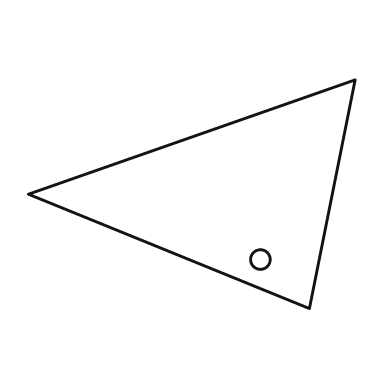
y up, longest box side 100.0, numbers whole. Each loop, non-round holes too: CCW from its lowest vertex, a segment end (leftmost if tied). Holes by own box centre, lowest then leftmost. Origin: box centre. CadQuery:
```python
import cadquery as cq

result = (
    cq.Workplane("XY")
    .moveTo(36.0, -35.0)
    .lineTo(50.0, 35.0)
    .lineTo(-50.0, 0.0)
    .close()
    .moveTo(21.0, -20.0)
    .circle(3.0)
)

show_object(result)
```